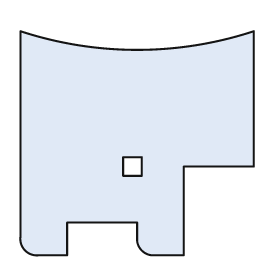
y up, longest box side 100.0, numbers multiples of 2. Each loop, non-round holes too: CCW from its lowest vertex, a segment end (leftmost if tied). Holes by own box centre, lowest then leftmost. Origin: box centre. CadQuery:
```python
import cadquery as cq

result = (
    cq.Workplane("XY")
    .moveTo(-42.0, -48.0)
    .lineTo(-30.0, -48.0)
    .lineTo(-30.0, -34.0)
    .lineTo(0.0, -34.0)
    .lineTo(0.0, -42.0)
    .threePointArc((2.0, -46.0), (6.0, -48.0))
    .lineTo(20.0, -48.0)
    .lineTo(20.0, -10.0)
    .lineTo(50.0, -10.0)
    .lineTo(50.0, 48.0)
    .threePointArc((0.0, 40.0), (-50.0, 48.0))
    .lineTo(-50.0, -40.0)
    .threePointArc((-48.0, -46.0), (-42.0, -48.0))
    .close()
    .moveTo(-6.0, -14.0)
    .lineTo(2.0, -14.0)
    .lineTo(2.0, -6.0)
    .lineTo(-6.0, -6.0)
    .close()
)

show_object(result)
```